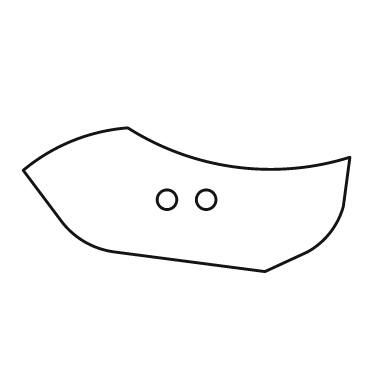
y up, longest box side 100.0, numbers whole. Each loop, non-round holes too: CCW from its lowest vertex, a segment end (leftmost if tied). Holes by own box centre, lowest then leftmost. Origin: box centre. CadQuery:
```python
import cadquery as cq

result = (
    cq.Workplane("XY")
    .moveTo(24.0, -22.0)
    .lineTo(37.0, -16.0)
    .threePointArc((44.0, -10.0), (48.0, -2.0))
    .lineTo(50.0, 13.0)
    .threePointArc((15.0, 10.0), (-18.0, 22.0))
    .threePointArc((-35.0, 18.0), (-50.0, 9.0))
    .lineTo(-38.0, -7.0)
    .threePointArc((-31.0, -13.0), (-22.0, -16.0))
    .close()
    .moveTo(-6.0, 0.0)
    .circle(3.0)
    .moveTo(6.0, 0.0)
    .circle(3.0)
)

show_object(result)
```